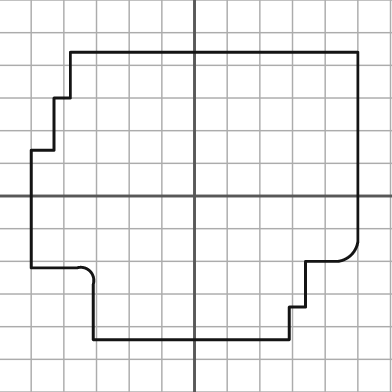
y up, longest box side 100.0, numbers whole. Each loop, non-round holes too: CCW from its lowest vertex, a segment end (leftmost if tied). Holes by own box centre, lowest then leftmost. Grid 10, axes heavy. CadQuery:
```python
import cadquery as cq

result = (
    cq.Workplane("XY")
    .moveTo(-31.0, -44.0)
    .lineTo(29.0, -44.0)
    .lineTo(29.0, -34.0)
    .lineTo(34.0, -34.0)
    .lineTo(34.0, -20.0)
    .lineTo(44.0, -20.0)
    .threePointArc((48.0, -18.0), (50.0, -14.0))
    .lineTo(50.0, 44.0)
    .lineTo(-38.0, 44.0)
    .lineTo(-38.0, 30.0)
    .lineTo(-43.0, 30.0)
    .lineTo(-43.0, 14.0)
    .lineTo(-50.0, 14.0)
    .lineTo(-50.0, -22.0)
    .lineTo(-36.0, -22.0)
    .threePointArc((-32.0, -23.0), (-31.0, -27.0))
    .close()
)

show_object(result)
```